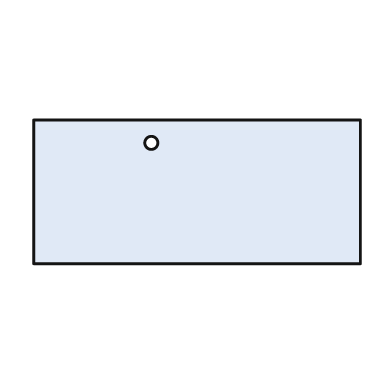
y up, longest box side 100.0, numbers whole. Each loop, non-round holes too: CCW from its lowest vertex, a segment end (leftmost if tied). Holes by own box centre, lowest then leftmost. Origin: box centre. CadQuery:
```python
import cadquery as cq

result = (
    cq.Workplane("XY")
    .moveTo(-50.0, -22.0)
    .lineTo(50.0, -22.0)
    .lineTo(50.0, 22.0)
    .lineTo(-50.0, 22.0)
    .close()
    .moveTo(-14.0, 15.0)
    .circle(2.0)
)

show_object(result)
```